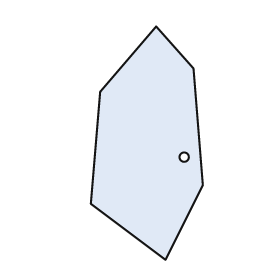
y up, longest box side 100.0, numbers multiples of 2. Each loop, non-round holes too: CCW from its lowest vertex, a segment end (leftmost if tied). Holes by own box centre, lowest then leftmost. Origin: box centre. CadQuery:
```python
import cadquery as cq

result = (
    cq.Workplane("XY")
    .moveTo(8.0, -50.0)
    .lineTo(24.0, -18.0)
    .lineTo(20.0, 32.0)
    .lineTo(4.0, 50.0)
    .lineTo(-20.0, 22.0)
    .lineTo(-24.0, -26.0)
    .close()
    .moveTo(16.0, -6.0)
    .circle(2.0)
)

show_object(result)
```